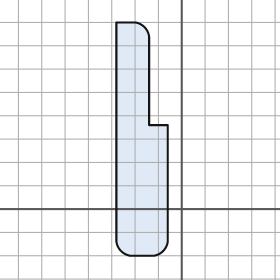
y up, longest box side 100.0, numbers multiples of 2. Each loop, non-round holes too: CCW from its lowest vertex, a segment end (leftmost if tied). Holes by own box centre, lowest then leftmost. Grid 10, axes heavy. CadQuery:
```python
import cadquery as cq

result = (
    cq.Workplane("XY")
    .moveTo(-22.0, -20.0)
    .lineTo(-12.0, -20.0)
    .threePointArc((-8.0, -18.0), (-6.0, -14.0))
    .lineTo(-6.0, 36.0)
    .lineTo(-14.0, 36.0)
    .lineTo(-14.0, 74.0)
    .threePointArc((-16.0, 78.0), (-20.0, 80.0))
    .lineTo(-28.0, 80.0)
    .lineTo(-28.0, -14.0)
    .threePointArc((-26.0, -18.0), (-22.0, -20.0))
    .close()
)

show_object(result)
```